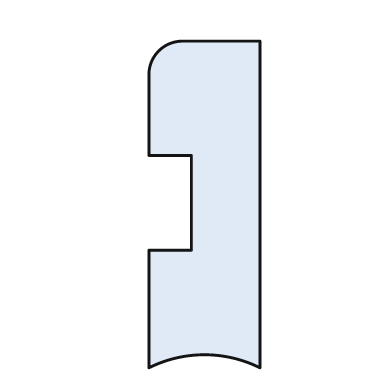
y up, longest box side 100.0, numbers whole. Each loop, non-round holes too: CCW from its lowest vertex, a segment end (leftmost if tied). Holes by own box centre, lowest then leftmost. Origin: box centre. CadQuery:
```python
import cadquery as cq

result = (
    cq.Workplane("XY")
    .moveTo(-17.0, -50.0)
    .threePointArc((0.0, -46.0), (17.0, -50.0))
    .lineTo(17.0, 50.0)
    .lineTo(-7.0, 50.0)
    .threePointArc((-14.0, 47.0), (-17.0, 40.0))
    .lineTo(-17.0, 15.0)
    .lineTo(-4.0, 15.0)
    .lineTo(-4.0, -14.0)
    .lineTo(-17.0, -14.0)
    .close()
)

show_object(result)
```